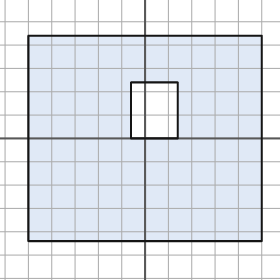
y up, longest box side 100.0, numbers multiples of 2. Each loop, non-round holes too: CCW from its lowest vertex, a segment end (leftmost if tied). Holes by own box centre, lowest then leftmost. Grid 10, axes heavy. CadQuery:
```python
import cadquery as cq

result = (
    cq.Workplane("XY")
    .moveTo(-50.0, -44.0)
    .lineTo(50.0, -44.0)
    .lineTo(50.0, 44.0)
    .lineTo(-50.0, 44.0)
    .close()
    .moveTo(-6.0, 0.0)
    .lineTo(14.0, 0.0)
    .lineTo(14.0, 24.0)
    .lineTo(-6.0, 24.0)
    .close()
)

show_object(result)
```